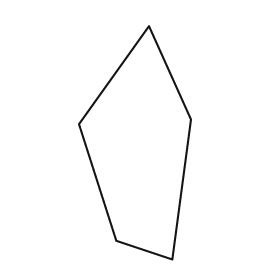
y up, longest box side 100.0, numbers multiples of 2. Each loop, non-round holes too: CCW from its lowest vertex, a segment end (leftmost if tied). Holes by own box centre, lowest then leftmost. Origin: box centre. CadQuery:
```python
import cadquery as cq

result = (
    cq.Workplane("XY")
    .moveTo(16.0, -50.0)
    .lineTo(24.0, 10.0)
    .lineTo(6.0, 50.0)
    .lineTo(-24.0, 8.0)
    .lineTo(-8.0, -42.0)
    .close()
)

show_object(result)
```